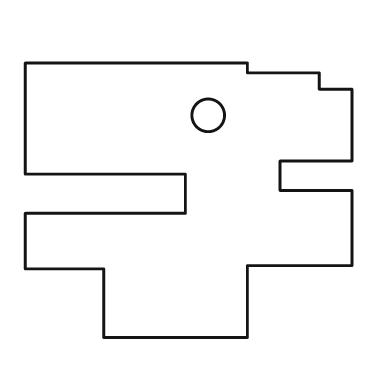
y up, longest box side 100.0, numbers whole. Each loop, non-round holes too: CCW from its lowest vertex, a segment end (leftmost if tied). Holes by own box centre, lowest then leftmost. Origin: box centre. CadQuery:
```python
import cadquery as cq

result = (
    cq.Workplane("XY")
    .moveTo(-26.0, -42.0)
    .lineTo(18.0, -42.0)
    .lineTo(18.0, -20.0)
    .lineTo(50.0, -20.0)
    .lineTo(50.0, 3.0)
    .lineTo(28.0, 3.0)
    .lineTo(28.0, 12.0)
    .lineTo(50.0, 12.0)
    .lineTo(50.0, 34.0)
    .lineTo(40.0, 34.0)
    .lineTo(40.0, 39.0)
    .lineTo(18.0, 39.0)
    .lineTo(18.0, 42.0)
    .lineTo(-50.0, 42.0)
    .lineTo(-50.0, 8.0)
    .lineTo(-1.0, 8.0)
    .lineTo(-1.0, -4.0)
    .lineTo(-50.0, -4.0)
    .lineTo(-50.0, -21.0)
    .lineTo(-26.0, -21.0)
    .close()
    .moveTo(6.0, 26.0)
    .circle(5.0)
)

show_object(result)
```